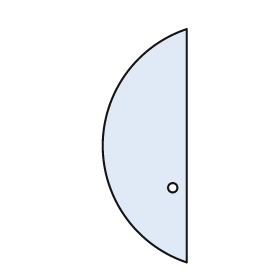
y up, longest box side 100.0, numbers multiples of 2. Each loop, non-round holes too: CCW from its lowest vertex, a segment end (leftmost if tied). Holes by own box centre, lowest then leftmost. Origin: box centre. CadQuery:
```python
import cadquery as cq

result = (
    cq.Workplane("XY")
    .moveTo(18.0, -50.0)
    .lineTo(18.0, 50.0)
    .threePointArc((-18.0, 0.0), (18.0, -50.0))
    .close()
    .moveTo(12.0, -18.0)
    .circle(2.0)
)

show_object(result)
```